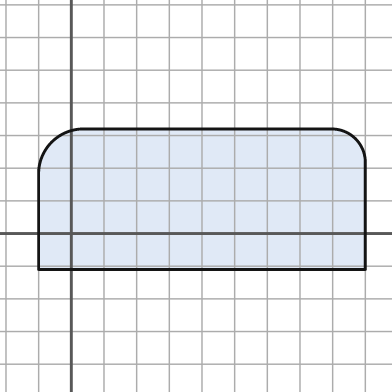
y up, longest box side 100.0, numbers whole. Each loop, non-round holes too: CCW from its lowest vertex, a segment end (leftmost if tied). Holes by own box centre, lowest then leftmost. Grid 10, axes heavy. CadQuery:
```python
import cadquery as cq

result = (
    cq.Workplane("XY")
    .moveTo(-10.0, -11.0)
    .lineTo(90.0, -11.0)
    .lineTo(90.0, 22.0)
    .threePointArc((87.0, 29.0), (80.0, 32.0))
    .lineTo(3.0, 32.0)
    .threePointArc((-6.0, 28.0), (-10.0, 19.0))
    .close()
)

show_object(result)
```